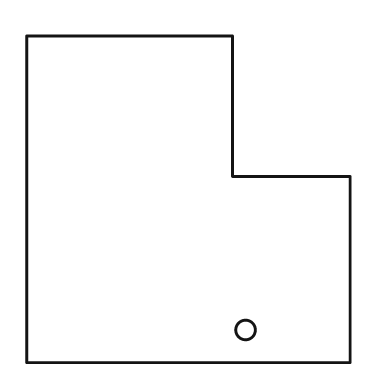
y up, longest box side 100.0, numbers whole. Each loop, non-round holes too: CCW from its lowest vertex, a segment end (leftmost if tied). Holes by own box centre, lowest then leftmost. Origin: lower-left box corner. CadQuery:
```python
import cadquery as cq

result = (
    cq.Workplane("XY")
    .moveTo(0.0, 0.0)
    .lineTo(99.0, 0.0)
    .lineTo(99.0, 57.0)
    .lineTo(63.0, 57.0)
    .lineTo(63.0, 100.0)
    .lineTo(0.0, 100.0)
    .close()
    .moveTo(67.0, 10.0)
    .circle(3.0)
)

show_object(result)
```